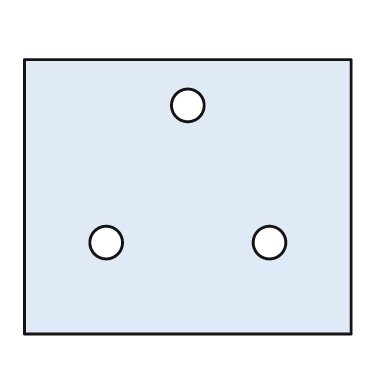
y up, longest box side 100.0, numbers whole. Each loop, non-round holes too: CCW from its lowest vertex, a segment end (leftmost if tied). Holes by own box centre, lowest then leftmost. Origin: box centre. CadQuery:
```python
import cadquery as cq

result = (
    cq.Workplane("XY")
    .moveTo(-50.0, -42.0)
    .lineTo(50.0, -42.0)
    .lineTo(50.0, 42.0)
    .lineTo(-50.0, 42.0)
    .close()
    .moveTo(-25.0, -14.0)
    .circle(5.0)
    .moveTo(25.0, -14.0)
    .circle(5.0)
    .moveTo(0.0, 28.0)
    .circle(5.0)
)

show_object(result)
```